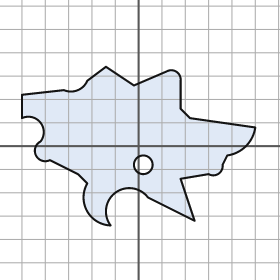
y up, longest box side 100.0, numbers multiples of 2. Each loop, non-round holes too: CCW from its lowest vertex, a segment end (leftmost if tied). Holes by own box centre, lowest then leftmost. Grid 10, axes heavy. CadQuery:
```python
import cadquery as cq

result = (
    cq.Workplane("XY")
    .moveTo(-12.0, -34.0)
    .threePointArc((-10.0, -20.0), (4.0, -22.0))
    .lineTo(24.0, -32.0)
    .lineTo(18.0, -14.0)
    .lineTo(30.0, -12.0)
    .threePointArc((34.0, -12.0), (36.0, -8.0))
    .lineTo(38.0, -4.0)
    .threePointArc((46.0, 0.0), (50.0, 8.0))
    .lineTo(22.0, 12.0)
    .lineTo(18.0, 16.0)
    .lineTo(18.0, 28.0)
    .threePointArc((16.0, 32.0), (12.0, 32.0))
    .lineTo(-2.0, 26.0)
    .lineTo(-14.0, 34.0)
    .lineTo(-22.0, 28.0)
    .threePointArc((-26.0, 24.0), (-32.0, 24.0))
    .lineTo(-50.0, 22.0)
    .lineTo(-50.0, 12.0)
    .threePointArc((-42.0, 10.0), (-42.0, 2.0))
    .threePointArc((-44.0, -4.0), (-38.0, -6.0))
    .lineTo(-26.0, -12.0)
    .lineTo(-22.0, -16.0)
    .threePointArc((-22.0, -28.0), (-12.0, -34.0))
    .close()
    .moveTo(2.0, -8.0)
    .circle(4.0)
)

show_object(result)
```